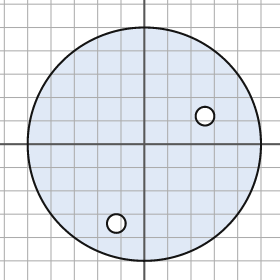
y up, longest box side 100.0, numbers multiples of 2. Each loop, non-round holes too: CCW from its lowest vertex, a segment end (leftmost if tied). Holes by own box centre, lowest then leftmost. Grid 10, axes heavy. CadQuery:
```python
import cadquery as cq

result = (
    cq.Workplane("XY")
    .moveTo(0.0, 0.0)
    .circle(50.0)
    .moveTo(-12.0, -34.0)
    .circle(4.0)
    .moveTo(26.0, 12.0)
    .circle(4.0)
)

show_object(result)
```